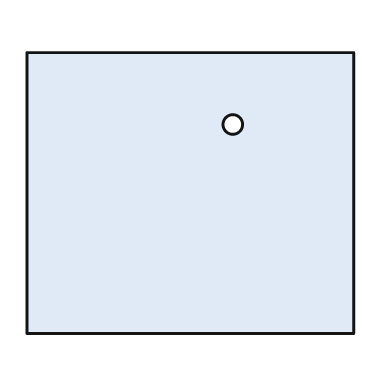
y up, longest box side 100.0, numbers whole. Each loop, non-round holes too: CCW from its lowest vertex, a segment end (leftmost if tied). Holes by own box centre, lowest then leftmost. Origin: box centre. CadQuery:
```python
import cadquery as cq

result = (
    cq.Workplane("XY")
    .moveTo(-50.0, -43.0)
    .lineTo(50.0, -43.0)
    .lineTo(50.0, 43.0)
    .lineTo(-50.0, 43.0)
    .close()
    .moveTo(13.0, 21.0)
    .circle(3.0)
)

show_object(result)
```